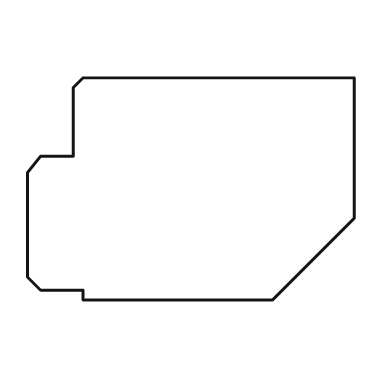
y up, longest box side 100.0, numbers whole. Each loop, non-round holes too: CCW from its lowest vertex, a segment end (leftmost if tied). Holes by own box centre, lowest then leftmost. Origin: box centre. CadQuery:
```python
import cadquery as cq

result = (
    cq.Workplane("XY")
    .moveTo(-33.0, -34.0)
    .lineTo(25.0, -34.0)
    .lineTo(50.0, -9.0)
    .lineTo(50.0, 34.0)
    .lineTo(-33.0, 34.0)
    .lineTo(-36.0, 31.0)
    .lineTo(-36.0, 10.0)
    .lineTo(-46.0, 10.0)
    .lineTo(-50.0, 5.0)
    .lineTo(-50.0, -27.0)
    .lineTo(-46.0, -31.0)
    .lineTo(-33.0, -31.0)
    .close()
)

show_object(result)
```